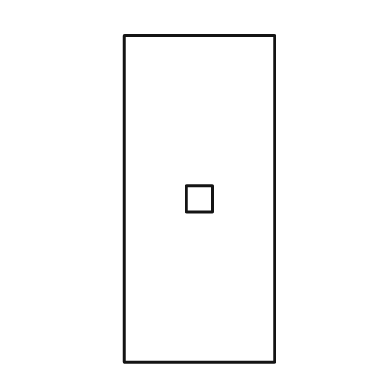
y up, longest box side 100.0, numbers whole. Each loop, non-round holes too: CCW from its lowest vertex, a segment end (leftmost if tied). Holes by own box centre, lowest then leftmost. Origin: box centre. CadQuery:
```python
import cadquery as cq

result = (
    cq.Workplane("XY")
    .moveTo(-23.0, -50.0)
    .lineTo(23.0, -50.0)
    .lineTo(23.0, 50.0)
    .lineTo(-23.0, 50.0)
    .close()
    .moveTo(-4.0, -4.0)
    .lineTo(4.0, -4.0)
    .lineTo(4.0, 4.0)
    .lineTo(-4.0, 4.0)
    .close()
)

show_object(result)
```